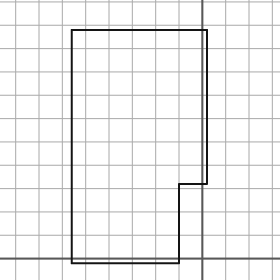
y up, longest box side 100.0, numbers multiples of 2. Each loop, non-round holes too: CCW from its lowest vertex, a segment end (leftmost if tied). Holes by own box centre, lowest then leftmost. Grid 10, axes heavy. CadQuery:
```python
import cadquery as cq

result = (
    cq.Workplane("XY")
    .moveTo(-56.0, -2.0)
    .lineTo(-10.0, -2.0)
    .lineTo(-10.0, 32.0)
    .lineTo(2.0, 32.0)
    .lineTo(2.0, 98.0)
    .lineTo(-56.0, 98.0)
    .close()
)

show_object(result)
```